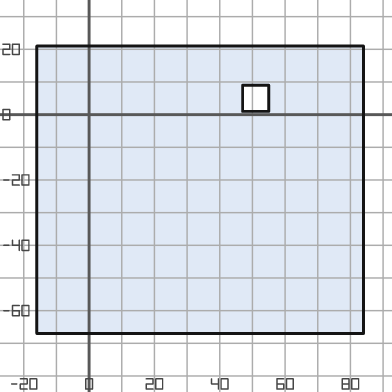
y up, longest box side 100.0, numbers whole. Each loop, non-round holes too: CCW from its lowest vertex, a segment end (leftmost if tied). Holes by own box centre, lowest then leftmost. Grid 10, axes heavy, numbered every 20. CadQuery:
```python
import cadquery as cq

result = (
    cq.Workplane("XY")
    .moveTo(-16.0, -67.0)
    .lineTo(84.0, -67.0)
    .lineTo(84.0, 21.0)
    .lineTo(-16.0, 21.0)
    .close()
    .moveTo(47.0, 1.0)
    .lineTo(55.0, 1.0)
    .lineTo(55.0, 9.0)
    .lineTo(47.0, 9.0)
    .close()
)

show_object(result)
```